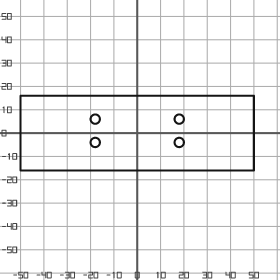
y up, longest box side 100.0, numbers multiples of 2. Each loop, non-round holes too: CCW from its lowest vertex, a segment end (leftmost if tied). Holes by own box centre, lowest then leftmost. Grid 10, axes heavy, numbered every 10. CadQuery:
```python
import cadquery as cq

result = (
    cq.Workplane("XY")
    .moveTo(-50.0, -16.0)
    .lineTo(50.0, -16.0)
    .lineTo(50.0, 16.0)
    .lineTo(-50.0, 16.0)
    .close()
    .moveTo(-18.0, -4.0)
    .circle(2.0)
    .moveTo(18.0, -4.0)
    .circle(2.0)
    .moveTo(-18.0, 6.0)
    .circle(2.0)
    .moveTo(18.0, 6.0)
    .circle(2.0)
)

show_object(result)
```